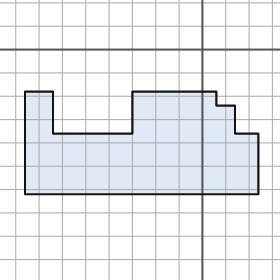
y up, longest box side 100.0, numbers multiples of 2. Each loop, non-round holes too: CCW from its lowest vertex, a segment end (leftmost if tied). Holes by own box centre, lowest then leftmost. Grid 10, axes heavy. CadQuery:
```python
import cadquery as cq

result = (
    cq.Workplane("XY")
    .moveTo(-76.0, -62.0)
    .lineTo(24.0, -62.0)
    .lineTo(24.0, -36.0)
    .lineTo(14.0, -36.0)
    .lineTo(14.0, -24.0)
    .lineTo(6.0, -24.0)
    .lineTo(6.0, -18.0)
    .lineTo(-30.0, -18.0)
    .lineTo(-30.0, -36.0)
    .lineTo(-64.0, -36.0)
    .lineTo(-64.0, -18.0)
    .lineTo(-76.0, -18.0)
    .close()
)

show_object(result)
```